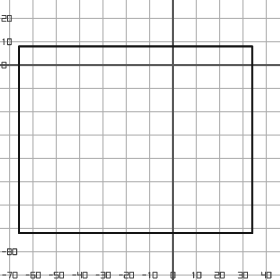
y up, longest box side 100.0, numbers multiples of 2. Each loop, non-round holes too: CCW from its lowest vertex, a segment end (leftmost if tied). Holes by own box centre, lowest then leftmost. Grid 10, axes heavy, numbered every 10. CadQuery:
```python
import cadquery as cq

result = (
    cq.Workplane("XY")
    .moveTo(-66.0, -72.0)
    .lineTo(34.0, -72.0)
    .lineTo(34.0, 8.0)
    .lineTo(-66.0, 8.0)
    .close()
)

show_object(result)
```